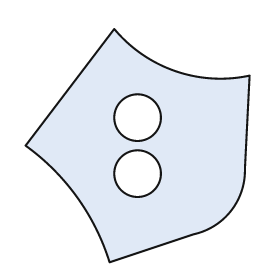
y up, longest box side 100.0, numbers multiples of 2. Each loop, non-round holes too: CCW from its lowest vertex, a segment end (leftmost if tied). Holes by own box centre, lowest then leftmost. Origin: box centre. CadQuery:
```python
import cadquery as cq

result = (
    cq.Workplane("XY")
    .moveTo(-12.0, -50.0)
    .lineTo(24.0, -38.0)
    .threePointArc((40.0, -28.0), (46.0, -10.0))
    .lineTo(48.0, 30.0)
    .threePointArc((16.0, 32.0), (-10.0, 50.0))
    .lineTo(-48.0, 0.0)
    .threePointArc((-26.0, -22.0), (-12.0, -50.0))
    .close()
    .moveTo(0.0, -12.0)
    .circle(10.0)
    .moveTo(0.0, 12.0)
    .circle(10.0)
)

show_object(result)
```